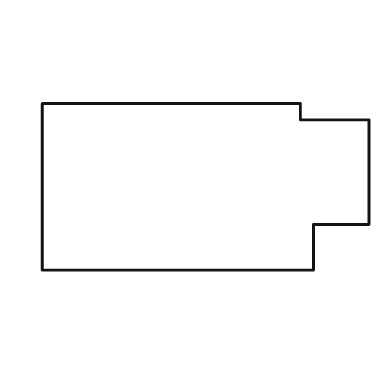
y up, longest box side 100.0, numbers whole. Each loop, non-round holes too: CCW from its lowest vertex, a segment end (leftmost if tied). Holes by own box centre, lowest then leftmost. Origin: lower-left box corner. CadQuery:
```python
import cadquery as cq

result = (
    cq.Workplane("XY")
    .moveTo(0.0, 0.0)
    .lineTo(83.0, 0.0)
    .lineTo(83.0, 14.0)
    .lineTo(100.0, 14.0)
    .lineTo(100.0, 46.0)
    .lineTo(79.0, 46.0)
    .lineTo(79.0, 51.0)
    .lineTo(0.0, 51.0)
    .close()
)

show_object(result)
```